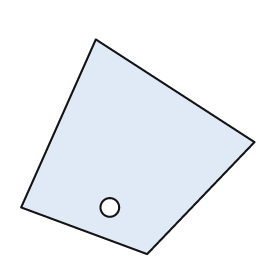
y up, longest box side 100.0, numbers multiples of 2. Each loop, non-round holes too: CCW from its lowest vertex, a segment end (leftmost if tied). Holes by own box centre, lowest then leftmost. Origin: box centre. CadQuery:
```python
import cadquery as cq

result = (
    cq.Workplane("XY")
    .moveTo(4.0, -46.0)
    .lineTo(50.0, 2.0)
    .lineTo(-18.0, 46.0)
    .lineTo(-50.0, -26.0)
    .close()
    .moveTo(-12.0, -26.0)
    .circle(4.0)
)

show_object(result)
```